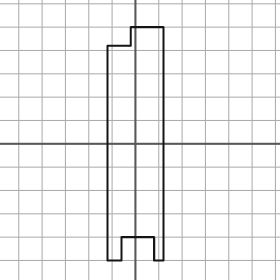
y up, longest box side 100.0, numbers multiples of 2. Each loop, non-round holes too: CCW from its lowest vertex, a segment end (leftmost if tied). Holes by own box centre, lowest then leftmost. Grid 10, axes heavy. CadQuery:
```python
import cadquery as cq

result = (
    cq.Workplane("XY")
    .moveTo(-12.0, -50.0)
    .lineTo(-6.0, -50.0)
    .lineTo(-6.0, -40.0)
    .lineTo(8.0, -40.0)
    .lineTo(8.0, -50.0)
    .lineTo(12.0, -50.0)
    .lineTo(12.0, 50.0)
    .lineTo(-2.0, 50.0)
    .lineTo(-2.0, 42.0)
    .lineTo(-12.0, 42.0)
    .close()
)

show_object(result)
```